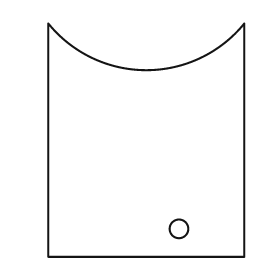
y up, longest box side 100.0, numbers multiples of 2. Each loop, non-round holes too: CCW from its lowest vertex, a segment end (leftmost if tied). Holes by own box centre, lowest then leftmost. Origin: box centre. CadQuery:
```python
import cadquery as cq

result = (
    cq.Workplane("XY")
    .moveTo(-42.0, -50.0)
    .lineTo(42.0, -50.0)
    .lineTo(42.0, 50.0)
    .threePointArc((0.0, 30.0), (-42.0, 50.0))
    .close()
    .moveTo(14.0, -38.0)
    .circle(4.0)
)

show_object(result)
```